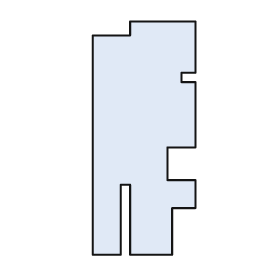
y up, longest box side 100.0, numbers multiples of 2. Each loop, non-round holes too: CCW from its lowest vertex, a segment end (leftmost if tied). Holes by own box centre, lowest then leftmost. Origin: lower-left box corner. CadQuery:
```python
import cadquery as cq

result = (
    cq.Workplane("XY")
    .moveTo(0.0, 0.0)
    .lineTo(12.0, 0.0)
    .lineTo(12.0, 30.0)
    .lineTo(16.0, 30.0)
    .lineTo(16.0, 0.0)
    .lineTo(34.0, 0.0)
    .lineTo(34.0, 20.0)
    .lineTo(44.0, 20.0)
    .lineTo(44.0, 32.0)
    .lineTo(32.0, 32.0)
    .lineTo(32.0, 46.0)
    .lineTo(44.0, 46.0)
    .lineTo(44.0, 74.0)
    .lineTo(38.0, 74.0)
    .lineTo(38.0, 78.0)
    .lineTo(44.0, 78.0)
    .lineTo(44.0, 100.0)
    .lineTo(16.0, 100.0)
    .lineTo(16.0, 94.0)
    .lineTo(0.0, 94.0)
    .close()
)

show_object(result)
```